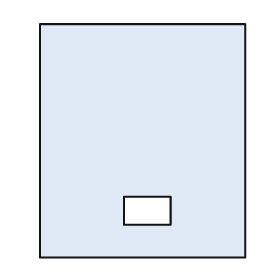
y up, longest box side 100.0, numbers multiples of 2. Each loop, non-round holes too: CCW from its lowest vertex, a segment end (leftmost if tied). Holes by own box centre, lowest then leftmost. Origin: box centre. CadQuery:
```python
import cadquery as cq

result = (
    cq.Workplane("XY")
    .moveTo(-44.0, -50.0)
    .lineTo(44.0, -50.0)
    .lineTo(44.0, 50.0)
    .lineTo(-44.0, 50.0)
    .close()
    .moveTo(-8.0, -36.0)
    .lineTo(12.0, -36.0)
    .lineTo(12.0, -24.0)
    .lineTo(-8.0, -24.0)
    .close()
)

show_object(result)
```